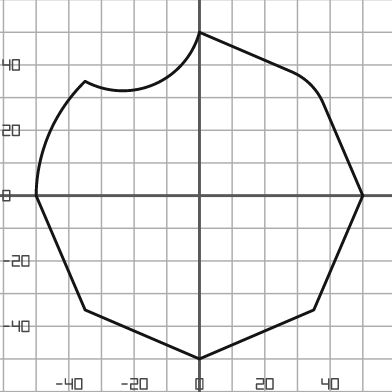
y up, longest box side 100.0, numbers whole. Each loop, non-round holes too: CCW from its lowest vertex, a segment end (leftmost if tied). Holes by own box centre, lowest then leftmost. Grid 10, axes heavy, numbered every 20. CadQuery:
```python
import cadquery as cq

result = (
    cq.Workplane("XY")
    .moveTo(0.0, -50.0)
    .lineTo(35.0, -35.0)
    .lineTo(50.0, 0.0)
    .lineTo(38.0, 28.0)
    .threePointArc((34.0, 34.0), (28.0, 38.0))
    .lineTo(0.0, 50.0)
    .threePointArc((-14.0, 34.0), (-35.0, 35.0))
    .threePointArc((-46.0, 19.0), (-50.0, 0.0))
    .lineTo(-35.0, -35.0)
    .close()
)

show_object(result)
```